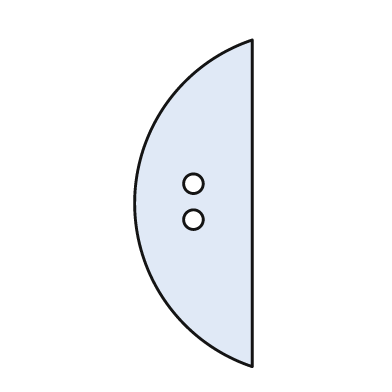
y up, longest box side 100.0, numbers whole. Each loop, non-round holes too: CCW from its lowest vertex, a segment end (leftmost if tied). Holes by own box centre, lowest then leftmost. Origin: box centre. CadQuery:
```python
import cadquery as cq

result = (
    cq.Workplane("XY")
    .moveTo(18.0, -50.0)
    .lineTo(18.0, 50.0)
    .threePointArc((-18.0, 0.0), (18.0, -50.0))
    .close()
    .moveTo(0.0, -5.0)
    .circle(3.0)
    .moveTo(0.0, 6.0)
    .circle(3.0)
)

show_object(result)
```